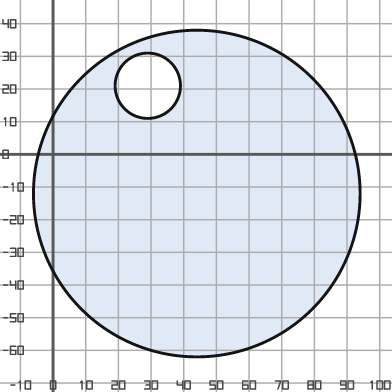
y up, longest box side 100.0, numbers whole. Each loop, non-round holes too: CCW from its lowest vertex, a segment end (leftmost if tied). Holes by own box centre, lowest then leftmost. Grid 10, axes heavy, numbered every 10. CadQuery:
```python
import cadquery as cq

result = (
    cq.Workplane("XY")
    .moveTo(44.0, -12.0)
    .circle(50.0)
    .moveTo(29.0, 21.0)
    .circle(10.0)
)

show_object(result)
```